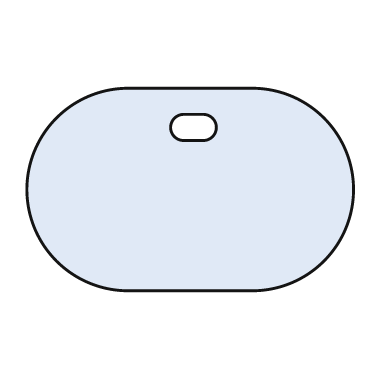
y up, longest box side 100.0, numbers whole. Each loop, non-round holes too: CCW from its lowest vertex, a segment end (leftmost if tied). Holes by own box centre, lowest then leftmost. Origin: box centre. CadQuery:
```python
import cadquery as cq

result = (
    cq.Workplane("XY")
    .moveTo(-19.0, -31.0)
    .lineTo(19.0, -31.0)
    .threePointArc((50.0, 0.0), (19.0, 31.0))
    .lineTo(-19.0, 31.0)
    .threePointArc((-50.0, 0.0), (-19.0, -31.0))
    .close()
    .moveTo(-2.0, 15.0)
    .lineTo(4.0, 15.0)
    .threePointArc((8.0, 19.0), (4.0, 23.0))
    .lineTo(-2.0, 23.0)
    .threePointArc((-6.0, 19.0), (-2.0, 15.0))
    .close()
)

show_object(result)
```